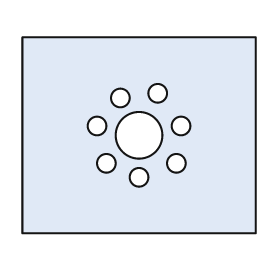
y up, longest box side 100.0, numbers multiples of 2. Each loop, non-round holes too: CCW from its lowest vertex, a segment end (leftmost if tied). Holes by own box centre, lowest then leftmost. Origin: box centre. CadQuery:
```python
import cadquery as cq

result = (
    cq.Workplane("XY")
    .moveTo(-50.0, -42.0)
    .lineTo(50.0, -42.0)
    .lineTo(50.0, 42.0)
    .lineTo(-50.0, 42.0)
    .close()
    .moveTo(0.0, -18.0)
    .circle(4.0)
    .moveTo(-14.0, -12.0)
    .circle(4.0)
    .moveTo(16.0, -12.0)
    .circle(4.0)
    .moveTo(0.0, 0.0)
    .circle(10.0)
    .moveTo(-18.0, 4.0)
    .circle(4.0)
    .moveTo(18.0, 4.0)
    .circle(4.0)
    .moveTo(-8.0, 16.0)
    .circle(4.0)
    .moveTo(8.0, 18.0)
    .circle(4.0)
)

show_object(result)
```